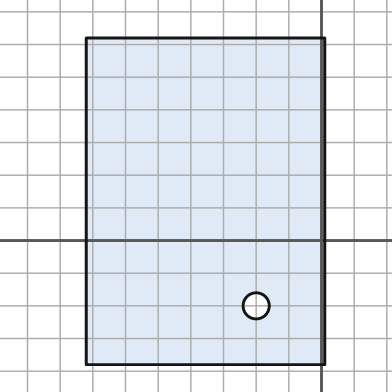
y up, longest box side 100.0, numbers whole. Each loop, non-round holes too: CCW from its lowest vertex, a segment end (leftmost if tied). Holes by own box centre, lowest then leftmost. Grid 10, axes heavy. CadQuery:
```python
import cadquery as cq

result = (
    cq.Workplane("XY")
    .moveTo(-72.0, -38.0)
    .lineTo(1.0, -38.0)
    .lineTo(1.0, 62.0)
    .lineTo(-72.0, 62.0)
    .close()
    .moveTo(-20.0, -20.0)
    .circle(4.0)
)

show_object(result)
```